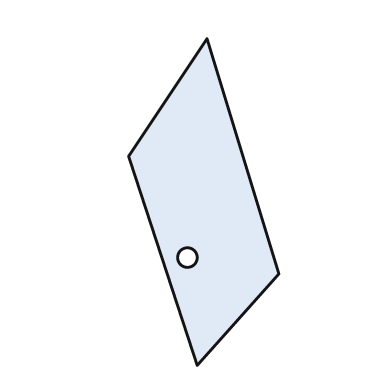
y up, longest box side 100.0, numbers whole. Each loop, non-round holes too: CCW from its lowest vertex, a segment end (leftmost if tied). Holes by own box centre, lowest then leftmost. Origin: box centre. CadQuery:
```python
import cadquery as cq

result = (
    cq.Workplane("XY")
    .moveTo(-2.0, -50.0)
    .lineTo(23.0, -22.0)
    .lineTo(1.0, 50.0)
    .lineTo(-23.0, 14.0)
    .close()
    .moveTo(-5.0, -17.0)
    .circle(3.0)
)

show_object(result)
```